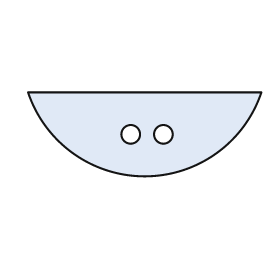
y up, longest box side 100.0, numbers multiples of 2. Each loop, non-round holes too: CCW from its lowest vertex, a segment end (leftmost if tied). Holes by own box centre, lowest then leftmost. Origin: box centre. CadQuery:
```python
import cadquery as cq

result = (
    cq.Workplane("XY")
    .moveTo(-50.0, 18.0)
    .threePointArc((0.0, -18.0), (50.0, 18.0))
    .close()
    .moveTo(-6.0, 0.0)
    .circle(4.0)
    .moveTo(8.0, 0.0)
    .circle(4.0)
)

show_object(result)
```